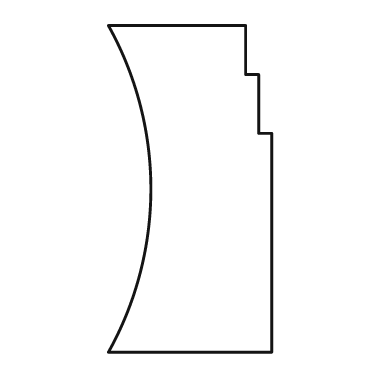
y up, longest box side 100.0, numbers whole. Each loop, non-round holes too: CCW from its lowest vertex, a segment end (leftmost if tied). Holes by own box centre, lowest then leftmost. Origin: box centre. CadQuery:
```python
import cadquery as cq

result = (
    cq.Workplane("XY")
    .moveTo(-25.0, -50.0)
    .lineTo(25.0, -50.0)
    .lineTo(25.0, 17.0)
    .lineTo(21.0, 17.0)
    .lineTo(21.0, 35.0)
    .lineTo(17.0, 35.0)
    .lineTo(17.0, 50.0)
    .lineTo(-25.0, 50.0)
    .threePointArc((-12.0, 0.0), (-25.0, -50.0))
    .close()
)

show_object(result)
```